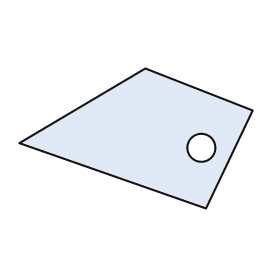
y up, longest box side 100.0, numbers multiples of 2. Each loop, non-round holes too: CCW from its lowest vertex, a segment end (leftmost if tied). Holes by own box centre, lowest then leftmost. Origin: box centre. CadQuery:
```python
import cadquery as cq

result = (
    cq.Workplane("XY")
    .moveTo(30.0, -30.0)
    .lineTo(50.0, 12.0)
    .lineTo(4.0, 30.0)
    .lineTo(-50.0, -2.0)
    .close()
    .moveTo(28.0, -4.0)
    .circle(6.0)
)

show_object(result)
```